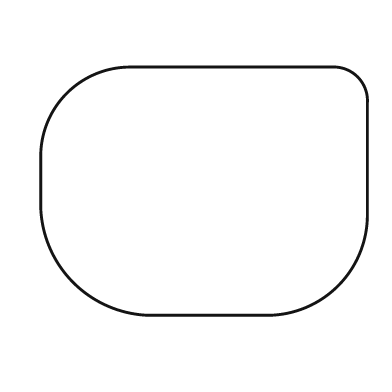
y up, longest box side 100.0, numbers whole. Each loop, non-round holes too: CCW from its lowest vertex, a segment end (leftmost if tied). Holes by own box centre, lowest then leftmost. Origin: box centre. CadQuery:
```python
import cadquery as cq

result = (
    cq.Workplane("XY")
    .moveTo(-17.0, -38.0)
    .lineTo(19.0, -38.0)
    .threePointArc((41.0, -29.0), (50.0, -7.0))
    .lineTo(50.0, 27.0)
    .threePointArc((47.0, 35.0), (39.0, 38.0))
    .lineTo(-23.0, 38.0)
    .threePointArc((-42.0, 30.0), (-50.0, 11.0))
    .lineTo(-50.0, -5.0)
    .threePointArc((-40.0, -28.0), (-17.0, -38.0))
    .close()
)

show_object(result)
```